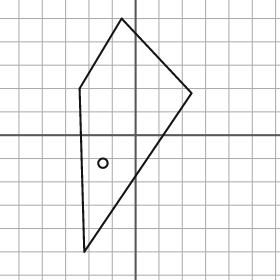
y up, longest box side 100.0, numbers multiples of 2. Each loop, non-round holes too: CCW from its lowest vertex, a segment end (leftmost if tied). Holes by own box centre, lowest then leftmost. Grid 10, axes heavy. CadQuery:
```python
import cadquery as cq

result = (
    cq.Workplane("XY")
    .moveTo(-22.0, -50.0)
    .lineTo(24.0, 18.0)
    .lineTo(-6.0, 50.0)
    .lineTo(-24.0, 20.0)
    .close()
    .moveTo(-14.0, -12.0)
    .circle(2.0)
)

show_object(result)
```